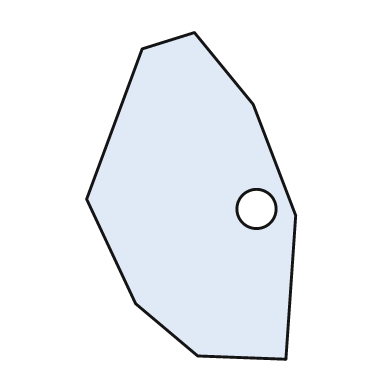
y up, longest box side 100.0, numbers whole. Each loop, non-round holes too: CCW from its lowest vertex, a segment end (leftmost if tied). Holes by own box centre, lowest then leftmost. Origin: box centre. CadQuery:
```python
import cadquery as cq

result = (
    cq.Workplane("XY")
    .moveTo(29.0, -50.0)
    .lineTo(32.0, -6.0)
    .lineTo(19.0, 28.0)
    .lineTo(1.0, 50.0)
    .lineTo(-15.0, 45.0)
    .lineTo(-32.0, -1.0)
    .lineTo(-17.0, -33.0)
    .lineTo(2.0, -49.0)
    .close()
    .moveTo(20.0, -4.0)
    .circle(6.0)
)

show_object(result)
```